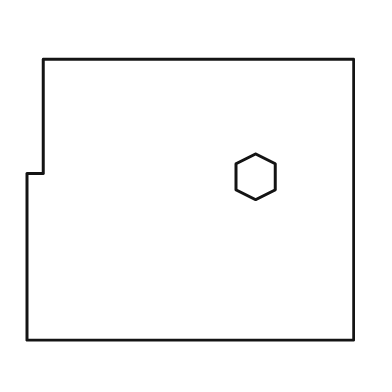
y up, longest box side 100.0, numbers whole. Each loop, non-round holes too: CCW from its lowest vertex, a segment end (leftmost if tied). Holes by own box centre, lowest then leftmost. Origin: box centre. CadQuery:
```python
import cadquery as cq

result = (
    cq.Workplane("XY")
    .moveTo(-50.0, -43.0)
    .lineTo(50.0, -43.0)
    .lineTo(50.0, 43.0)
    .lineTo(-45.0, 43.0)
    .lineTo(-45.0, 8.0)
    .lineTo(-50.0, 8.0)
    .close()
    .moveTo(20.0, 0.0)
    .lineTo(26.0, 3.0)
    .lineTo(26.0, 11.0)
    .lineTo(20.0, 14.0)
    .lineTo(14.0, 11.0)
    .lineTo(14.0, 3.0)
    .close()
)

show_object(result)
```